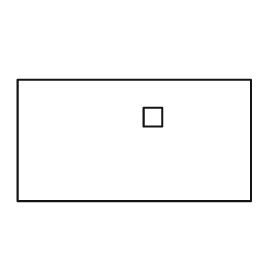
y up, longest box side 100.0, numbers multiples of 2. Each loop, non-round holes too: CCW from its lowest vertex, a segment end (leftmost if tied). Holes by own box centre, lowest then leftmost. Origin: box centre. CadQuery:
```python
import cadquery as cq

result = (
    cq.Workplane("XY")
    .moveTo(-50.0, -26.0)
    .lineTo(50.0, -26.0)
    .lineTo(50.0, 26.0)
    .lineTo(-50.0, 26.0)
    .close()
    .moveTo(4.0, 6.0)
    .lineTo(12.0, 6.0)
    .lineTo(12.0, 14.0)
    .lineTo(4.0, 14.0)
    .close()
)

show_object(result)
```